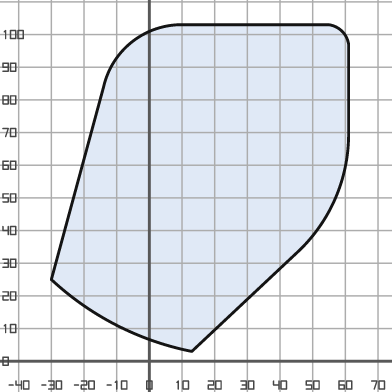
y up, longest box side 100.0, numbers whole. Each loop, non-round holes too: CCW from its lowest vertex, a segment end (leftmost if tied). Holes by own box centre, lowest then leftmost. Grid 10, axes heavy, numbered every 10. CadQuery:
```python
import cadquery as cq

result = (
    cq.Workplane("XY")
    .moveTo(13.0, 3.0)
    .lineTo(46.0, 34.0)
    .threePointArc((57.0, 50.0), (61.0, 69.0))
    .lineTo(61.0, 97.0)
    .threePointArc((59.0, 101.0), (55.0, 103.0))
    .lineTo(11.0, 103.0)
    .threePointArc((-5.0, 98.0), (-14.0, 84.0))
    .lineTo(-30.0, 25.0)
    .threePointArc((-10.0, 11.0), (13.0, 3.0))
    .close()
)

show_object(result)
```